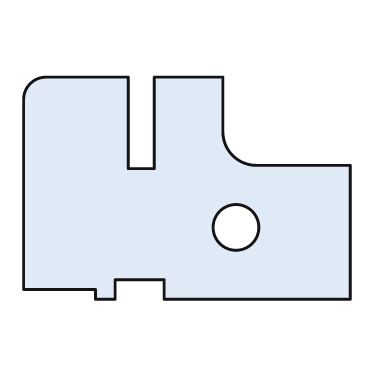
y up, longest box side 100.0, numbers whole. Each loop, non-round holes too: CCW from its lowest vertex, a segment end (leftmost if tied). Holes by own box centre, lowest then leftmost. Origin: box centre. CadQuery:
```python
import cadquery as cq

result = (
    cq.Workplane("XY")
    .moveTo(-28.0, -34.0)
    .lineTo(-22.0, -34.0)
    .lineTo(-22.0, -28.0)
    .lineTo(-7.0, -28.0)
    .lineTo(-7.0, -34.0)
    .lineTo(50.0, -34.0)
    .lineTo(50.0, 7.0)
    .lineTo(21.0, 7.0)
    .threePointArc((14.0, 10.0), (11.0, 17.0))
    .lineTo(11.0, 34.0)
    .lineTo(-10.0, 34.0)
    .lineTo(-10.0, 6.0)
    .lineTo(-18.0, 6.0)
    .lineTo(-18.0, 34.0)
    .lineTo(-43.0, 34.0)
    .threePointArc((-48.0, 32.0), (-50.0, 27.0))
    .lineTo(-50.0, -31.0)
    .lineTo(-28.0, -31.0)
    .close()
    .moveTo(15.0, -12.0)
    .circle(7.0)
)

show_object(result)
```